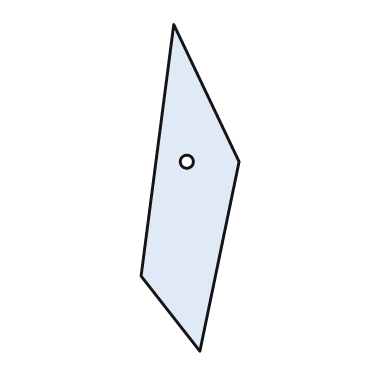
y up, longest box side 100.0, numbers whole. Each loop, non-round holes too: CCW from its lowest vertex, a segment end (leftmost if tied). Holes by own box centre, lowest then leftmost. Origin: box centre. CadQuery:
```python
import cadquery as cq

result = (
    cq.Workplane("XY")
    .moveTo(3.0, -50.0)
    .lineTo(15.0, 8.0)
    .lineTo(-5.0, 50.0)
    .lineTo(-15.0, -27.0)
    .close()
    .moveTo(-1.0, 8.0)
    .circle(2.0)
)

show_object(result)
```